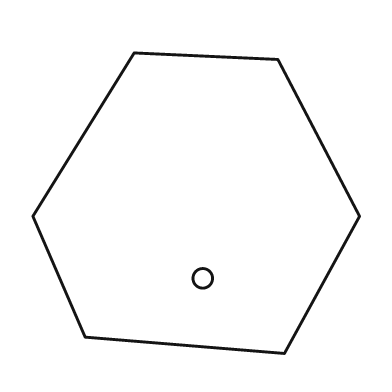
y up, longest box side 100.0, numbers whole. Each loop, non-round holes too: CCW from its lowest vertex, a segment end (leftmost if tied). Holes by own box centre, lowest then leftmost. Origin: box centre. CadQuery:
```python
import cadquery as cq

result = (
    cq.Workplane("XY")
    .moveTo(27.0, -46.0)
    .lineTo(50.0, -4.0)
    .lineTo(25.0, 44.0)
    .lineTo(-19.0, 46.0)
    .lineTo(-50.0, -4.0)
    .lineTo(-34.0, -41.0)
    .close()
    .moveTo(2.0, -23.0)
    .circle(3.0)
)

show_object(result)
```